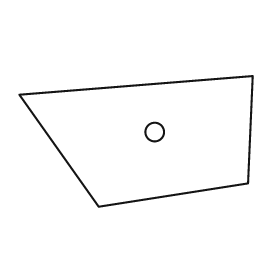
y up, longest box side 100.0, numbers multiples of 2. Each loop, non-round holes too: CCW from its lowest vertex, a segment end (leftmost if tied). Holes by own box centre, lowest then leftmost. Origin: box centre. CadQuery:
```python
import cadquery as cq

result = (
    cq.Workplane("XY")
    .moveTo(-16.0, -28.0)
    .lineTo(48.0, -18.0)
    .lineTo(50.0, 28.0)
    .lineTo(-50.0, 20.0)
    .close()
    .moveTo(8.0, 4.0)
    .circle(4.0)
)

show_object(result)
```